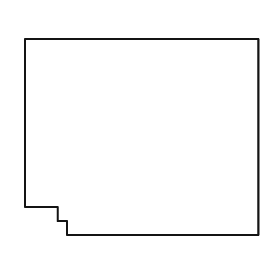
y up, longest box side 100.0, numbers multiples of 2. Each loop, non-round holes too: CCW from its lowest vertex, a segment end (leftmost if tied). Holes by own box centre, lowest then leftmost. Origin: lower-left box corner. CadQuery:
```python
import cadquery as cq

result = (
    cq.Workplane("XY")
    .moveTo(18.0, 0.0)
    .lineTo(100.0, 0.0)
    .lineTo(100.0, 84.0)
    .lineTo(0.0, 84.0)
    .lineTo(0.0, 12.0)
    .lineTo(14.0, 12.0)
    .lineTo(14.0, 6.0)
    .lineTo(18.0, 6.0)
    .close()
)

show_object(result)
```